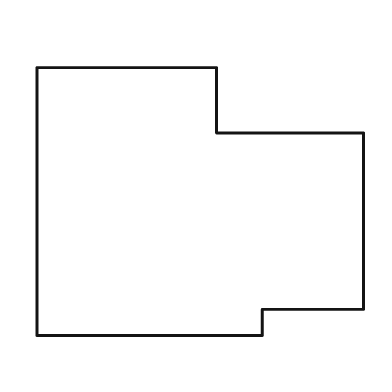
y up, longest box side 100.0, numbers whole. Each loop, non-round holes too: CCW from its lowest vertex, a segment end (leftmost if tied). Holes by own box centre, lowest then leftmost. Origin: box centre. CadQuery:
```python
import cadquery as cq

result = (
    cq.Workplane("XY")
    .moveTo(-50.0, -41.0)
    .lineTo(19.0, -41.0)
    .lineTo(19.0, -33.0)
    .lineTo(50.0, -33.0)
    .lineTo(50.0, 21.0)
    .lineTo(5.0, 21.0)
    .lineTo(5.0, 41.0)
    .lineTo(-50.0, 41.0)
    .close()
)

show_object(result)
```